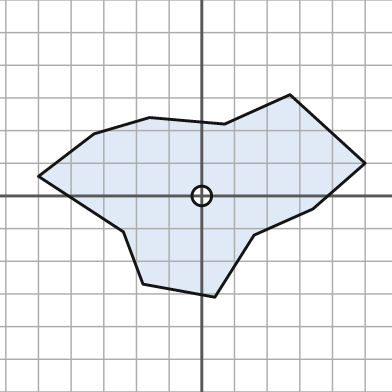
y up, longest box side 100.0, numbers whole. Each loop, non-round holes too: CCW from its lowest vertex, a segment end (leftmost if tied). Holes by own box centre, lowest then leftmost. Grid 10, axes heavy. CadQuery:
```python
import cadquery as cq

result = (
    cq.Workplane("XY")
    .moveTo(4.0, -31.0)
    .lineTo(16.0, -12.0)
    .lineTo(34.0, -4.0)
    .lineTo(50.0, 10.0)
    .lineTo(27.0, 31.0)
    .lineTo(7.0, 22.0)
    .lineTo(-16.0, 24.0)
    .lineTo(-33.0, 19.0)
    .lineTo(-50.0, 6.0)
    .lineTo(-24.0, -11.0)
    .lineTo(-18.0, -27.0)
    .close()
    .moveTo(0.0, 0.0)
    .circle(3.0)
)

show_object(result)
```